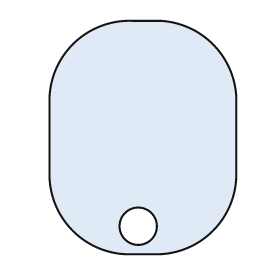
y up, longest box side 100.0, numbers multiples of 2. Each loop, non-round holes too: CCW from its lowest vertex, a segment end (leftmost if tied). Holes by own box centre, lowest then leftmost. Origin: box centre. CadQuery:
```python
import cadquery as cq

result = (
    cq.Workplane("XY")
    .moveTo(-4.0, -50.0)
    .lineTo(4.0, -50.0)
    .threePointArc((30.0, -40.0), (40.0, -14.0))
    .lineTo(40.0, 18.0)
    .threePointArc((30.0, 40.0), (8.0, 50.0))
    .lineTo(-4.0, 50.0)
    .threePointArc((-30.0, 40.0), (-40.0, 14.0))
    .lineTo(-40.0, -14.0)
    .threePointArc((-30.0, -40.0), (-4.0, -50.0))
    .close()
    .moveTo(-2.0, -38.0)
    .circle(8.0)
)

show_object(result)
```